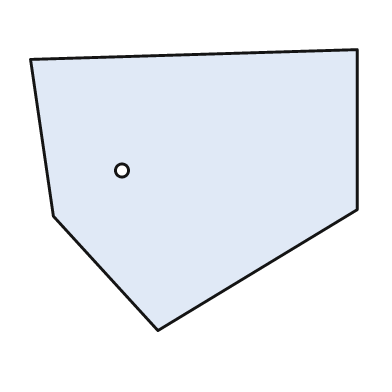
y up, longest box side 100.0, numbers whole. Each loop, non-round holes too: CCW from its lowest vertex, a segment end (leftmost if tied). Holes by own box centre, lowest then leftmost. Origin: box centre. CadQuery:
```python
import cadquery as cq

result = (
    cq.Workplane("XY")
    .moveTo(-11.0, -43.0)
    .lineTo(50.0, -6.0)
    .lineTo(50.0, 43.0)
    .lineTo(-50.0, 40.0)
    .lineTo(-43.0, -8.0)
    .close()
    .moveTo(-22.0, 6.0)
    .circle(2.0)
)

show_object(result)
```